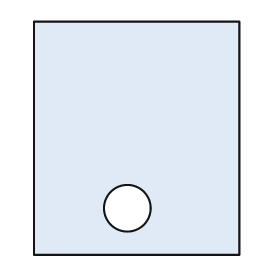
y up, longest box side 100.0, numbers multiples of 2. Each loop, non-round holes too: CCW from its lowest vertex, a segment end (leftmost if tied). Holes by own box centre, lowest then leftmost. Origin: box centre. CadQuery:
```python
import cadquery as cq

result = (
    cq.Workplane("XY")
    .moveTo(-44.0, -50.0)
    .lineTo(44.0, -50.0)
    .lineTo(44.0, 50.0)
    .lineTo(-44.0, 50.0)
    .close()
    .moveTo(-4.0, -30.0)
    .circle(10.0)
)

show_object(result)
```